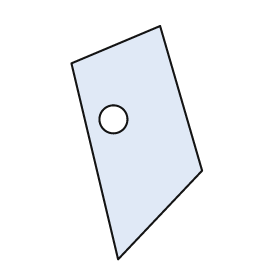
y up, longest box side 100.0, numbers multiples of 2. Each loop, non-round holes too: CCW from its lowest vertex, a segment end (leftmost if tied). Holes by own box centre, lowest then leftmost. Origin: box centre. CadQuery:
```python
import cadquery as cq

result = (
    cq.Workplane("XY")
    .moveTo(-8.0, -50.0)
    .lineTo(28.0, -12.0)
    .lineTo(10.0, 50.0)
    .lineTo(-28.0, 34.0)
    .close()
    .moveTo(-10.0, 10.0)
    .circle(6.0)
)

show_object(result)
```